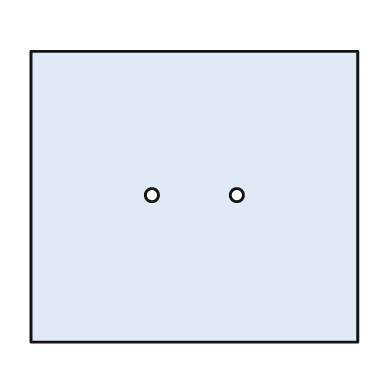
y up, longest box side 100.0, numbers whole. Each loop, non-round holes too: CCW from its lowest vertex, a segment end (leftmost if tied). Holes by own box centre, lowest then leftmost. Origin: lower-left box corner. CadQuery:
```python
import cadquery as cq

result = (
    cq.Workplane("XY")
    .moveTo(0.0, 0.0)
    .lineTo(100.0, 0.0)
    .lineTo(100.0, 89.0)
    .lineTo(0.0, 89.0)
    .close()
    .moveTo(37.0, 45.0)
    .circle(2.0)
    .moveTo(63.0, 45.0)
    .circle(2.0)
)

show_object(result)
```